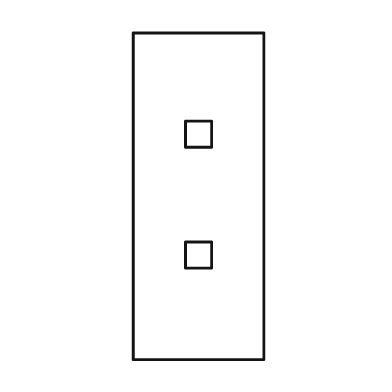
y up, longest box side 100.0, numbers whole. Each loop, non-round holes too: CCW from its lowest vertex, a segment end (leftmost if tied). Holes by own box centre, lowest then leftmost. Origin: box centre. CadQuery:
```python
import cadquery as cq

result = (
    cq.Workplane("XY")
    .moveTo(-20.0, -50.0)
    .lineTo(20.0, -50.0)
    .lineTo(20.0, 50.0)
    .lineTo(-20.0, 50.0)
    .close()
    .moveTo(-4.0, -22.0)
    .lineTo(4.0, -22.0)
    .lineTo(4.0, -14.0)
    .lineTo(-4.0, -14.0)
    .close()
    .moveTo(-4.0, 15.0)
    .lineTo(4.0, 15.0)
    .lineTo(4.0, 23.0)
    .lineTo(-4.0, 23.0)
    .close()
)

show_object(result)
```